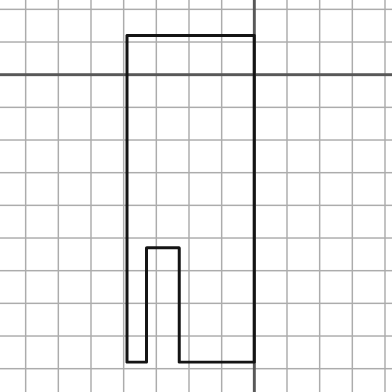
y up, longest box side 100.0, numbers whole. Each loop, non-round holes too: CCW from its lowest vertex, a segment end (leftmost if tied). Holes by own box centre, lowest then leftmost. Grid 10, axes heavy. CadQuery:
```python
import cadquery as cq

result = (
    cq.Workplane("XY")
    .moveTo(-39.0, -88.0)
    .lineTo(-33.0, -88.0)
    .lineTo(-33.0, -53.0)
    .lineTo(-23.0, -53.0)
    .lineTo(-23.0, -88.0)
    .lineTo(0.0, -88.0)
    .lineTo(0.0, 12.0)
    .lineTo(-39.0, 12.0)
    .close()
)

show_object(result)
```